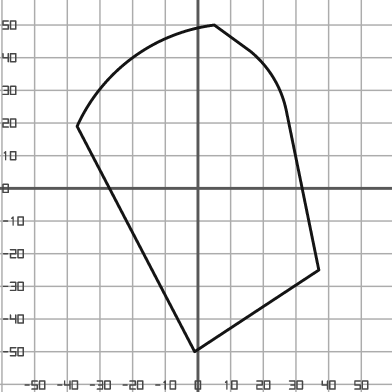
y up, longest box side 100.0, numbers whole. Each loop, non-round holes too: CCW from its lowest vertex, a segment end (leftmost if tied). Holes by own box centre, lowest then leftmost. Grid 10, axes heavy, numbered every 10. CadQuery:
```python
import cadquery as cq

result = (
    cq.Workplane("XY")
    .moveTo(-1.0, -50.0)
    .lineTo(37.0, -25.0)
    .lineTo(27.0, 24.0)
    .threePointArc((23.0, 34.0), (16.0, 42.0))
    .lineTo(5.0, 50.0)
    .threePointArc((-20.0, 40.0), (-37.0, 19.0))
    .close()
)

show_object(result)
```